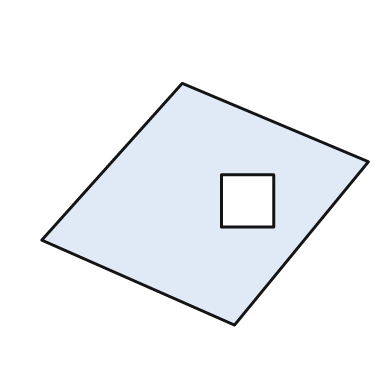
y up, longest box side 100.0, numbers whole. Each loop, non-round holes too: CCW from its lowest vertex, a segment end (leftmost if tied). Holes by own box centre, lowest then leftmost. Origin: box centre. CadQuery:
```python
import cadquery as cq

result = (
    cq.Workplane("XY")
    .moveTo(9.0, -37.0)
    .lineTo(50.0, 13.0)
    .lineTo(-7.0, 37.0)
    .lineTo(-50.0, -11.0)
    .close()
    .moveTo(5.0, -7.0)
    .lineTo(21.0, -7.0)
    .lineTo(21.0, 9.0)
    .lineTo(5.0, 9.0)
    .close()
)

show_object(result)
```